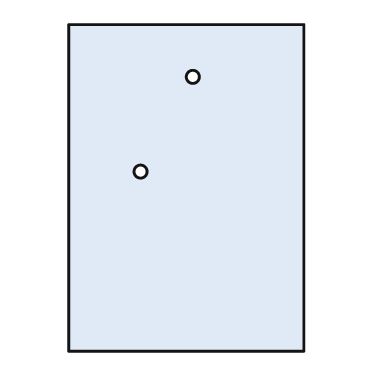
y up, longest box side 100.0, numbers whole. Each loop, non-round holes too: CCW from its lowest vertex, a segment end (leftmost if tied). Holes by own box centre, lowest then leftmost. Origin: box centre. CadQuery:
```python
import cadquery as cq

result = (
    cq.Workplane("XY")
    .moveTo(-36.0, -50.0)
    .lineTo(36.0, -50.0)
    .lineTo(36.0, 50.0)
    .lineTo(-36.0, 50.0)
    .close()
    .moveTo(-14.0, 5.0)
    .circle(2.0)
    .moveTo(2.0, 34.0)
    .circle(2.0)
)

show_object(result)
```